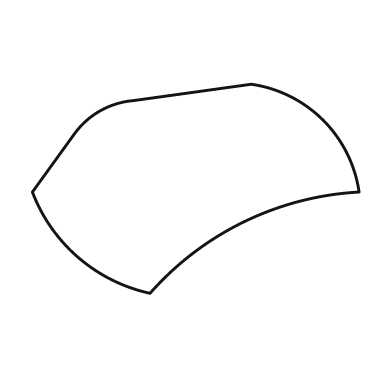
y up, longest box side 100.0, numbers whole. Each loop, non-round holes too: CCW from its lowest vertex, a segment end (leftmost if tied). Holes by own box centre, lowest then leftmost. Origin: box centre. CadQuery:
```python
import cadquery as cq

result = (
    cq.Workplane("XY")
    .moveTo(-14.0, -32.0)
    .threePointArc((15.0, -10.0), (50.0, -1.0))
    .threePointArc((39.0, 21.0), (17.0, 32.0))
    .lineTo(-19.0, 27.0)
    .threePointArc((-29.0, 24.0), (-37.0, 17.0))
    .lineTo(-50.0, -1.0)
    .threePointArc((-36.0, -21.0), (-14.0, -32.0))
    .close()
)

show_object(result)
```